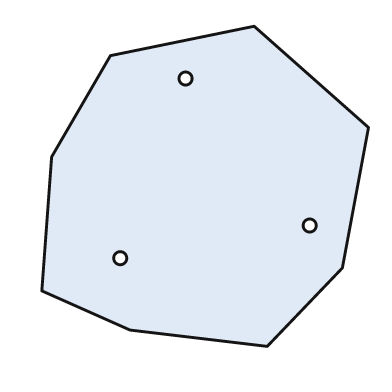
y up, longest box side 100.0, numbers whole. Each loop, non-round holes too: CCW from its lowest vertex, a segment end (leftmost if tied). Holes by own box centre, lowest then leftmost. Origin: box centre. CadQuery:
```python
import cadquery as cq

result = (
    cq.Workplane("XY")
    .moveTo(19.0, -49.0)
    .lineTo(42.0, -25.0)
    .lineTo(50.0, 18.0)
    .lineTo(15.0, 49.0)
    .lineTo(-29.0, 40.0)
    .lineTo(-47.0, 9.0)
    .lineTo(-50.0, -32.0)
    .lineTo(-23.0, -44.0)
    .close()
    .moveTo(-26.0, -22.0)
    .circle(2.0)
    .moveTo(32.0, -12.0)
    .circle(2.0)
    .moveTo(-6.0, 33.0)
    .circle(2.0)
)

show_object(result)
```